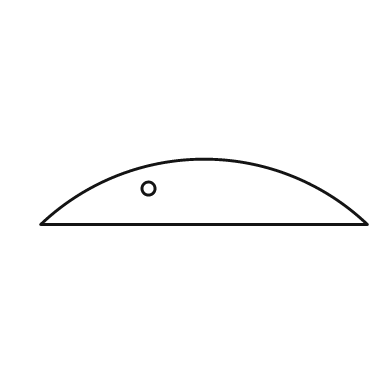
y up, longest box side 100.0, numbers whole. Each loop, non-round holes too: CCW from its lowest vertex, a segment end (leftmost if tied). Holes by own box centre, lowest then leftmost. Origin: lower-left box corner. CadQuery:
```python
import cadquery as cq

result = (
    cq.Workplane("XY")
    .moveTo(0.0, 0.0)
    .lineTo(100.0, 0.0)
    .threePointArc((50.0, 20.0), (0.0, 0.0))
    .close()
    .moveTo(33.0, 11.0)
    .circle(2.0)
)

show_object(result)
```